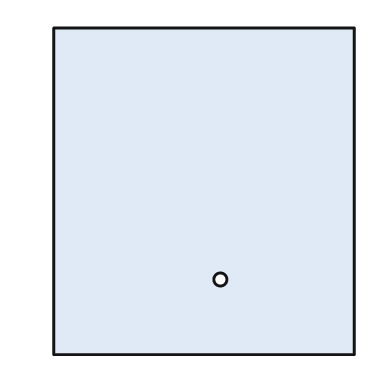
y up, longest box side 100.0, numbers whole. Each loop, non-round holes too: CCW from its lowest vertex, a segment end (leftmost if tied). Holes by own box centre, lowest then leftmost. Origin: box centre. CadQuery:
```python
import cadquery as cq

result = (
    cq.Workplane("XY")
    .moveTo(-46.0, -50.0)
    .lineTo(46.0, -50.0)
    .lineTo(46.0, 50.0)
    .lineTo(-46.0, 50.0)
    .close()
    .moveTo(5.0, -27.0)
    .circle(2.0)
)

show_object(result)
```